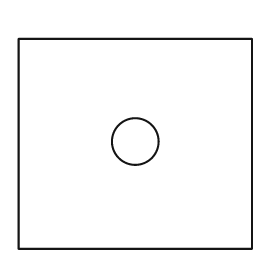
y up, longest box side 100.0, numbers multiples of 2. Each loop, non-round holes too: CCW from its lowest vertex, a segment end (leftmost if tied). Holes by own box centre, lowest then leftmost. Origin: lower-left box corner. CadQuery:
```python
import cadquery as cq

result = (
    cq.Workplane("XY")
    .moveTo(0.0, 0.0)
    .lineTo(100.0, 0.0)
    .lineTo(100.0, 90.0)
    .lineTo(0.0, 90.0)
    .close()
    .moveTo(50.0, 46.0)
    .circle(10.0)
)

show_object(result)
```